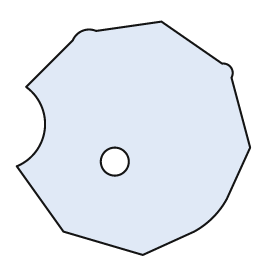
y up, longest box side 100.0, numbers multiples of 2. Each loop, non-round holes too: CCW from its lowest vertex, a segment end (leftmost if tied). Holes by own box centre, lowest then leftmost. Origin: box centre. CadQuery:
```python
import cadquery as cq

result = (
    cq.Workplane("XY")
    .moveTo(4.0, -50.0)
    .lineTo(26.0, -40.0)
    .threePointArc((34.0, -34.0), (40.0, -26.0))
    .lineTo(50.0, -4.0)
    .lineTo(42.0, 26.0)
    .threePointArc((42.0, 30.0), (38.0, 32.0))
    .lineTo(12.0, 50.0)
    .lineTo(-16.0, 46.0)
    .threePointArc((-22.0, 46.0), (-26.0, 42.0))
    .lineTo(-46.0, 22.0)
    .threePointArc((-38.0, 4.0), (-50.0, -12.0))
    .lineTo(-30.0, -40.0)
    .close()
    .moveTo(-8.0, -10.0)
    .circle(6.0)
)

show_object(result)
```